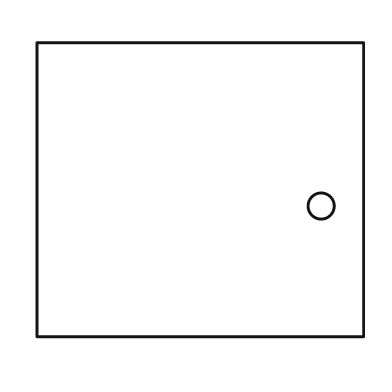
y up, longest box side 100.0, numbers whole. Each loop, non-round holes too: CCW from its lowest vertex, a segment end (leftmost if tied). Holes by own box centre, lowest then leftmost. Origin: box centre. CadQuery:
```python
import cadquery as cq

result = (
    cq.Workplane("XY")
    .moveTo(-50.0, -45.0)
    .lineTo(50.0, -45.0)
    .lineTo(50.0, 45.0)
    .lineTo(-50.0, 45.0)
    .close()
    .moveTo(37.0, -5.0)
    .circle(4.0)
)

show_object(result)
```